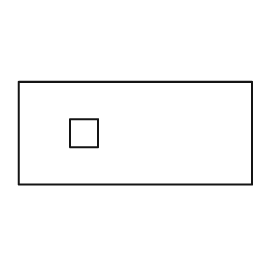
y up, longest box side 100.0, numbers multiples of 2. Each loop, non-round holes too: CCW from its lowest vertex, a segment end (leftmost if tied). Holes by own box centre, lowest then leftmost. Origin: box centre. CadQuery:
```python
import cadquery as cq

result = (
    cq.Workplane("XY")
    .moveTo(-50.0, -22.0)
    .lineTo(50.0, -22.0)
    .lineTo(50.0, 22.0)
    .lineTo(-50.0, 22.0)
    .close()
    .moveTo(-28.0, -6.0)
    .lineTo(-16.0, -6.0)
    .lineTo(-16.0, 6.0)
    .lineTo(-28.0, 6.0)
    .close()
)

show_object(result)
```